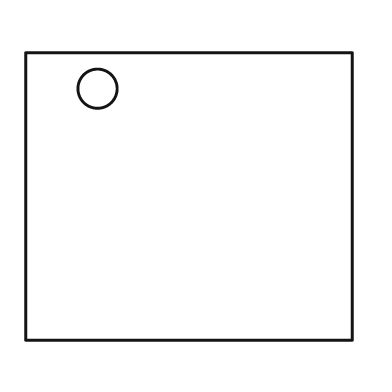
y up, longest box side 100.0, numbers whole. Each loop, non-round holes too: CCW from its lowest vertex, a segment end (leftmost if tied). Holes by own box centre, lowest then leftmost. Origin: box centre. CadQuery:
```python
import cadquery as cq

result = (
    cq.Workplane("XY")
    .moveTo(-50.0, -44.0)
    .lineTo(50.0, -44.0)
    .lineTo(50.0, 44.0)
    .lineTo(-50.0, 44.0)
    .close()
    .moveTo(-28.0, 33.0)
    .circle(6.0)
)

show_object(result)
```